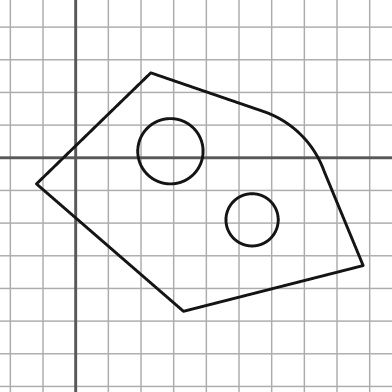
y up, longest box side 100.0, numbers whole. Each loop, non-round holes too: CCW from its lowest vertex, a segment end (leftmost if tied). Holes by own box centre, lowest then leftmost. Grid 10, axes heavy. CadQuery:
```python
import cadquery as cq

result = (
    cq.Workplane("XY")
    .moveTo(33.0, -47.0)
    .lineTo(88.0, -33.0)
    .lineTo(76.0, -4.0)
    .threePointArc((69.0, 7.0), (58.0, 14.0))
    .lineTo(23.0, 26.0)
    .lineTo(-12.0, -8.0)
    .close()
    .moveTo(54.0, -19.0)
    .circle(8.0)
    .moveTo(29.0, 2.0)
    .circle(10.0)
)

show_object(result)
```